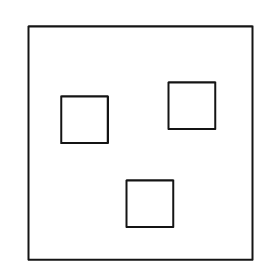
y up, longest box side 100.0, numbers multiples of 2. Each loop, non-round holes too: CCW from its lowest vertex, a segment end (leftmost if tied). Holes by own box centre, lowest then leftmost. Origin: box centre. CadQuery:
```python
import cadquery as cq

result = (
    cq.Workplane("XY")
    .moveTo(-48.0, -50.0)
    .lineTo(48.0, -50.0)
    .lineTo(48.0, 50.0)
    .lineTo(-48.0, 50.0)
    .close()
    .moveTo(-6.0, -36.0)
    .lineTo(14.0, -36.0)
    .lineTo(14.0, -16.0)
    .lineTo(-6.0, -16.0)
    .close()
    .moveTo(-34.0, 0.0)
    .lineTo(-14.0, 0.0)
    .lineTo(-14.0, 20.0)
    .lineTo(-34.0, 20.0)
    .close()
    .moveTo(12.0, 6.0)
    .lineTo(32.0, 6.0)
    .lineTo(32.0, 26.0)
    .lineTo(12.0, 26.0)
    .close()
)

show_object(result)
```